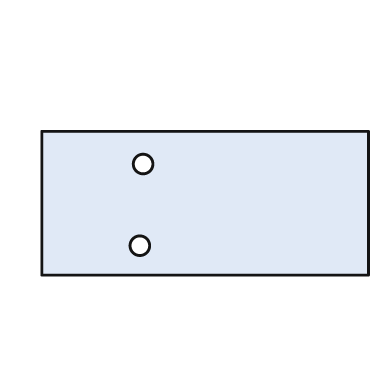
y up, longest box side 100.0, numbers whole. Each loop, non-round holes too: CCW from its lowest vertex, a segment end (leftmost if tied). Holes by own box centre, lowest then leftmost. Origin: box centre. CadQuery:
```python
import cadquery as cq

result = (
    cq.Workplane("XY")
    .moveTo(-50.0, -22.0)
    .lineTo(50.0, -22.0)
    .lineTo(50.0, 22.0)
    .lineTo(-50.0, 22.0)
    .close()
    .moveTo(-20.0, -13.0)
    .circle(3.0)
    .moveTo(-19.0, 12.0)
    .circle(3.0)
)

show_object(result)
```